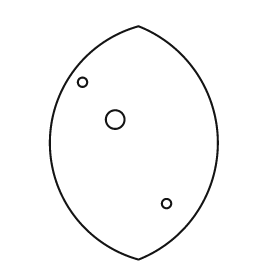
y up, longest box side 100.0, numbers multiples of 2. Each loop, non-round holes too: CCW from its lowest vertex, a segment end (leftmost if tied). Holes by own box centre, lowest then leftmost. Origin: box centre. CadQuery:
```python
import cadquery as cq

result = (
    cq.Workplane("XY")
    .moveTo(2.0, -50.0)
    .threePointArc((36.0, 0.0), (2.0, 50.0))
    .threePointArc((-36.0, 0.0), (2.0, -50.0))
    .close()
    .moveTo(14.0, -26.0)
    .circle(2.0)
    .moveTo(-8.0, 10.0)
    .circle(4.0)
    .moveTo(-22.0, 26.0)
    .circle(2.0)
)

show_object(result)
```